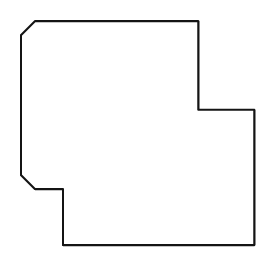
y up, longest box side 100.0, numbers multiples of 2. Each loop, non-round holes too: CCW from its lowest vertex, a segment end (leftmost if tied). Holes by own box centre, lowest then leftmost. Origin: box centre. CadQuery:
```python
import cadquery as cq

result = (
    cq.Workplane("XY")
    .moveTo(-32.0, -48.0)
    .lineTo(50.0, -48.0)
    .lineTo(50.0, 10.0)
    .lineTo(26.0, 10.0)
    .lineTo(26.0, 48.0)
    .lineTo(-44.0, 48.0)
    .lineTo(-50.0, 42.0)
    .lineTo(-50.0, -18.0)
    .lineTo(-44.0, -24.0)
    .lineTo(-32.0, -24.0)
    .close()
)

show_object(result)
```